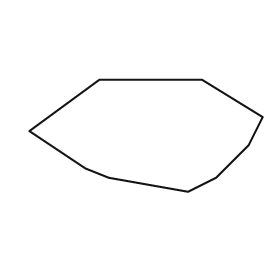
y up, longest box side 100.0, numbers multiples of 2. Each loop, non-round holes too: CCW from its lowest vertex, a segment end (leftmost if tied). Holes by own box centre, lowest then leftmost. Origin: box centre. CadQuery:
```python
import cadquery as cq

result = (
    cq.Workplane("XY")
    .moveTo(18.0, -24.0)
    .lineTo(30.0, -18.0)
    .lineTo(44.0, -4.0)
    .lineTo(50.0, 8.0)
    .lineTo(24.0, 24.0)
    .lineTo(-20.0, 24.0)
    .lineTo(-50.0, 2.0)
    .lineTo(-26.0, -14.0)
    .lineTo(-16.0, -18.0)
    .close()
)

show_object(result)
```